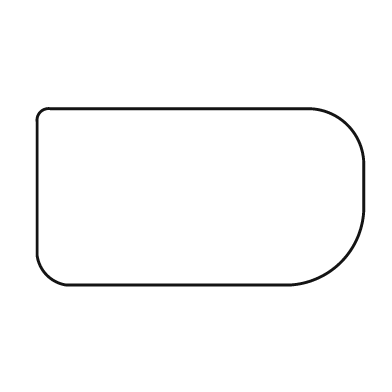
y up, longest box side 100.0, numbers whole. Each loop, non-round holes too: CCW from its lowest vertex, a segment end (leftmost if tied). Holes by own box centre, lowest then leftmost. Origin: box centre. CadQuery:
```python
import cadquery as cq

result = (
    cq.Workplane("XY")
    .moveTo(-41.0, -27.0)
    .lineTo(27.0, -27.0)
    .threePointArc((43.0, -20.0), (50.0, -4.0))
    .lineTo(50.0, 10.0)
    .threePointArc((45.0, 22.0), (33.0, 27.0))
    .lineTo(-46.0, 27.0)
    .threePointArc((-49.0, 26.0), (-50.0, 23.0))
    .lineTo(-50.0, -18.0)
    .threePointArc((-47.0, -24.0), (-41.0, -27.0))
    .close()
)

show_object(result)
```